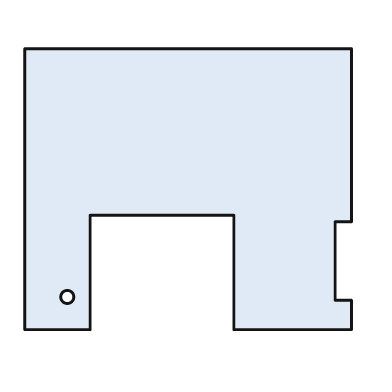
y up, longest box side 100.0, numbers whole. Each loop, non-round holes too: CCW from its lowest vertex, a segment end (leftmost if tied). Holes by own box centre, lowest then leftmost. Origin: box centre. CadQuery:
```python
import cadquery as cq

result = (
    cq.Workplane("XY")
    .moveTo(-50.0, -43.0)
    .lineTo(-30.0, -43.0)
    .lineTo(-30.0, -8.0)
    .lineTo(14.0, -8.0)
    .lineTo(14.0, -43.0)
    .lineTo(50.0, -43.0)
    .lineTo(50.0, -34.0)
    .lineTo(45.0, -34.0)
    .lineTo(45.0, -10.0)
    .lineTo(50.0, -10.0)
    .lineTo(50.0, 43.0)
    .lineTo(-50.0, 43.0)
    .close()
    .moveTo(-37.0, -33.0)
    .circle(2.0)
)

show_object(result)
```